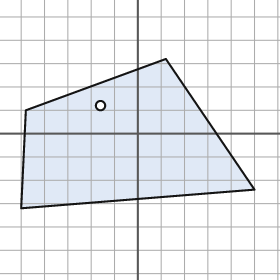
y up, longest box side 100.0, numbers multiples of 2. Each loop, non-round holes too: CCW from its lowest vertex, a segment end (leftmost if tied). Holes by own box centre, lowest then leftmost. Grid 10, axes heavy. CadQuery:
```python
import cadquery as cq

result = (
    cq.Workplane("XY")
    .moveTo(-50.0, -32.0)
    .lineTo(50.0, -24.0)
    .lineTo(12.0, 32.0)
    .lineTo(-48.0, 10.0)
    .close()
    .moveTo(-16.0, 12.0)
    .circle(2.0)
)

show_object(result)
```